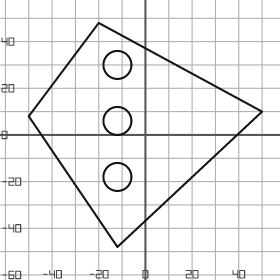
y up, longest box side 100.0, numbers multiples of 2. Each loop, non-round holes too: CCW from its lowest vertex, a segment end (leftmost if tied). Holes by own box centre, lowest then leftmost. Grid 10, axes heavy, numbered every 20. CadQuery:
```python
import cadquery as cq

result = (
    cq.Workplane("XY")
    .moveTo(-12.0, -48.0)
    .lineTo(50.0, 10.0)
    .lineTo(-20.0, 48.0)
    .lineTo(-50.0, 8.0)
    .close()
    .moveTo(-12.0, -18.0)
    .circle(6.0)
    .moveTo(-12.0, 6.0)
    .circle(6.0)
    .moveTo(-12.0, 30.0)
    .circle(6.0)
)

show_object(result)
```